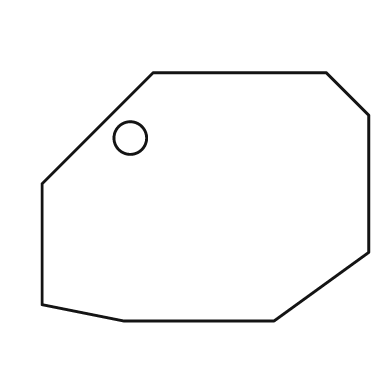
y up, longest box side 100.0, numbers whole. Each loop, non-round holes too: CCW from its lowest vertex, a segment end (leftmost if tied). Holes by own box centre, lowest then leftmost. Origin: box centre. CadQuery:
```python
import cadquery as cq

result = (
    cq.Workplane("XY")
    .moveTo(-25.0, -38.0)
    .lineTo(21.0, -38.0)
    .lineTo(50.0, -17.0)
    .lineTo(50.0, 25.0)
    .lineTo(37.0, 38.0)
    .lineTo(-16.0, 38.0)
    .lineTo(-50.0, 4.0)
    .lineTo(-50.0, -33.0)
    .close()
    .moveTo(-23.0, 18.0)
    .circle(5.0)
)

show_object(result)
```